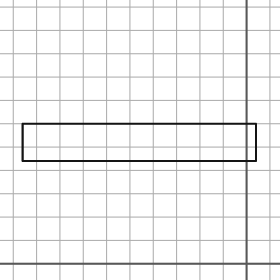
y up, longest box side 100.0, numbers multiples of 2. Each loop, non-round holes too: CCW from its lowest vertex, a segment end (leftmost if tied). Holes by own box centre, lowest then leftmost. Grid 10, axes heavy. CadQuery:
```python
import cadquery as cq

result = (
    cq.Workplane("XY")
    .moveTo(-96.0, 44.0)
    .lineTo(4.0, 44.0)
    .lineTo(4.0, 60.0)
    .lineTo(-96.0, 60.0)
    .close()
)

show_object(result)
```